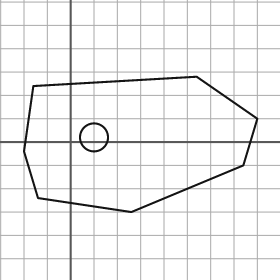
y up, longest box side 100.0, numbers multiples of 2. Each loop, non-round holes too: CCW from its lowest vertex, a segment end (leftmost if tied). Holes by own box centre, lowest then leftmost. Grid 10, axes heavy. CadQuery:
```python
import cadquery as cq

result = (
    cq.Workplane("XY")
    .moveTo(26.0, -30.0)
    .lineTo(74.0, -10.0)
    .lineTo(80.0, 10.0)
    .lineTo(54.0, 28.0)
    .lineTo(-16.0, 24.0)
    .lineTo(-20.0, -4.0)
    .lineTo(-14.0, -24.0)
    .close()
    .moveTo(10.0, 2.0)
    .circle(6.0)
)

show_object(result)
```